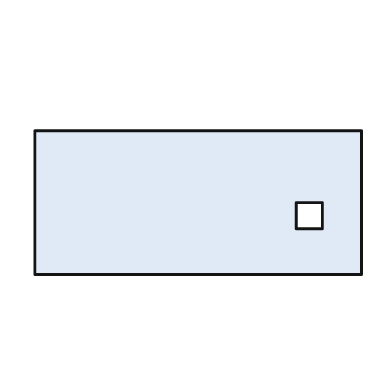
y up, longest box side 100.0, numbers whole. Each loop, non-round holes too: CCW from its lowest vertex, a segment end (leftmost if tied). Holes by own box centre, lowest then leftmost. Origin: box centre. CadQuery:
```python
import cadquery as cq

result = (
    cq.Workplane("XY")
    .moveTo(-50.0, -22.0)
    .lineTo(50.0, -22.0)
    .lineTo(50.0, 22.0)
    .lineTo(-50.0, 22.0)
    .close()
    .moveTo(30.0, -8.0)
    .lineTo(38.0, -8.0)
    .lineTo(38.0, 0.0)
    .lineTo(30.0, 0.0)
    .close()
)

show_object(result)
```